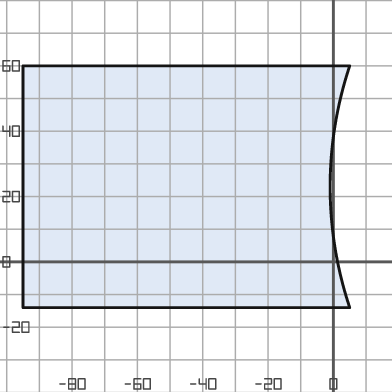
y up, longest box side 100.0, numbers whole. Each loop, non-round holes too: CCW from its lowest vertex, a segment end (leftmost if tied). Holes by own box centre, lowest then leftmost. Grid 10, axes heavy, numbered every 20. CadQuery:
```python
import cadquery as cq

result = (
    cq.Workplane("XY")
    .moveTo(-95.0, -14.0)
    .lineTo(5.0, -14.0)
    .threePointArc((-1.0, 23.0), (5.0, 60.0))
    .lineTo(-95.0, 60.0)
    .close()
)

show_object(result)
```